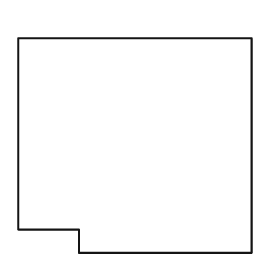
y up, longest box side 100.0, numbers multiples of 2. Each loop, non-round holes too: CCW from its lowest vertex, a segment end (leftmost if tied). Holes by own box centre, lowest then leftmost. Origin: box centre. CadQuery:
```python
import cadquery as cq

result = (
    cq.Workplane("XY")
    .moveTo(-24.0, -46.0)
    .lineTo(50.0, -46.0)
    .lineTo(50.0, 46.0)
    .lineTo(-50.0, 46.0)
    .lineTo(-50.0, -36.0)
    .lineTo(-24.0, -36.0)
    .close()
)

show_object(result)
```